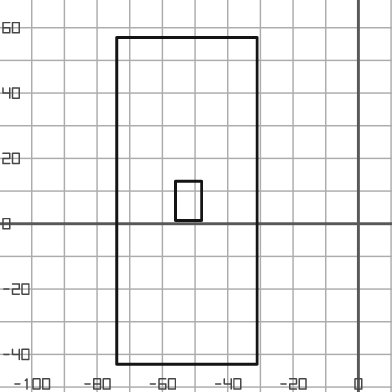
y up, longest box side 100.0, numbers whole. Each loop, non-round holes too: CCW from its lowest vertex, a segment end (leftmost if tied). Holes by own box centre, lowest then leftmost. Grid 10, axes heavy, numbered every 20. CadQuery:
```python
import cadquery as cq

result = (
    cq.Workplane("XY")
    .moveTo(-74.0, -43.0)
    .lineTo(-31.0, -43.0)
    .lineTo(-31.0, 57.0)
    .lineTo(-74.0, 57.0)
    .close()
    .moveTo(-56.0, 1.0)
    .lineTo(-48.0, 1.0)
    .lineTo(-48.0, 13.0)
    .lineTo(-56.0, 13.0)
    .close()
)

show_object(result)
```